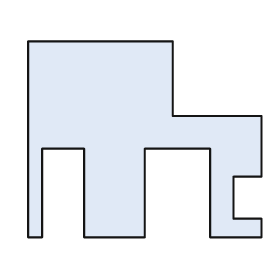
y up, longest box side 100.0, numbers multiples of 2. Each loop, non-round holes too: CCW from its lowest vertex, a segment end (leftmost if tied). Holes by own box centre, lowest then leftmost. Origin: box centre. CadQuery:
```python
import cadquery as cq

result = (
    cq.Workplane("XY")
    .moveTo(-50.0, -42.0)
    .lineTo(-44.0, -42.0)
    .lineTo(-44.0, -4.0)
    .lineTo(-26.0, -4.0)
    .lineTo(-26.0, -42.0)
    .lineTo(0.0, -42.0)
    .lineTo(0.0, -4.0)
    .lineTo(28.0, -4.0)
    .lineTo(28.0, -42.0)
    .lineTo(50.0, -42.0)
    .lineTo(50.0, -34.0)
    .lineTo(38.0, -34.0)
    .lineTo(38.0, -16.0)
    .lineTo(50.0, -16.0)
    .lineTo(50.0, 10.0)
    .lineTo(12.0, 10.0)
    .lineTo(12.0, 42.0)
    .lineTo(-50.0, 42.0)
    .close()
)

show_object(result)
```